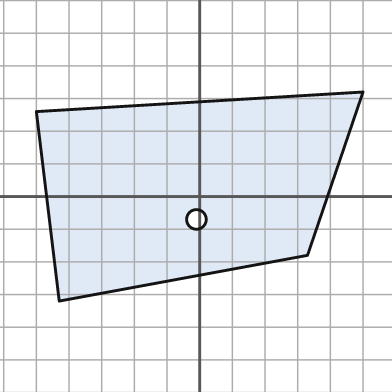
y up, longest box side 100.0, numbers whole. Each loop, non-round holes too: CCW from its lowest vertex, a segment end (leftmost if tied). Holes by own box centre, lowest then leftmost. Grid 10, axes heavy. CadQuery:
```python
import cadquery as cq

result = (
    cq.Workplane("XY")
    .moveTo(-43.0, -32.0)
    .lineTo(33.0, -18.0)
    .lineTo(50.0, 32.0)
    .lineTo(-50.0, 26.0)
    .close()
    .moveTo(-1.0, -7.0)
    .circle(3.0)
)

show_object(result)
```